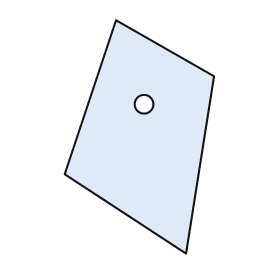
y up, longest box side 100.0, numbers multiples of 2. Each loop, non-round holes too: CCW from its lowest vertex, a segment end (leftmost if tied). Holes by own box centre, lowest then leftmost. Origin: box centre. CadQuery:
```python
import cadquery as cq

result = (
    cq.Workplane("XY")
    .moveTo(20.0, -50.0)
    .lineTo(32.0, 26.0)
    .lineTo(-10.0, 50.0)
    .lineTo(-32.0, -16.0)
    .close()
    .moveTo(2.0, 14.0)
    .circle(4.0)
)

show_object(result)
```